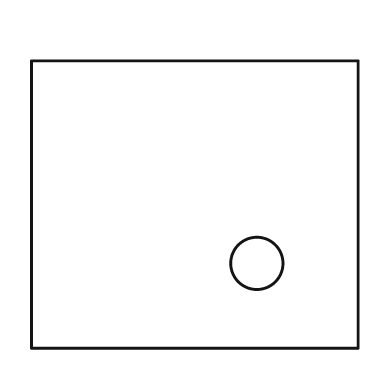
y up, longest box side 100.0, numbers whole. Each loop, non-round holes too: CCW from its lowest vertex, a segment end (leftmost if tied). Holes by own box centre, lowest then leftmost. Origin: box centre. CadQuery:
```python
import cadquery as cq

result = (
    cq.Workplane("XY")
    .moveTo(-50.0, -44.0)
    .lineTo(50.0, -44.0)
    .lineTo(50.0, 44.0)
    .lineTo(-50.0, 44.0)
    .close()
    .moveTo(19.0, -18.0)
    .circle(8.0)
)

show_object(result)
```